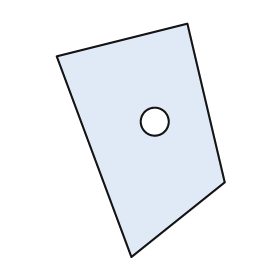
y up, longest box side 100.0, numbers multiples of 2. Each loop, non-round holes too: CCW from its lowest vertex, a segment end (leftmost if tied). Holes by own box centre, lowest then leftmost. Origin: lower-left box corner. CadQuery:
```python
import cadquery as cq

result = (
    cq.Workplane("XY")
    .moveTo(32.0, 0.0)
    .lineTo(72.0, 32.0)
    .lineTo(56.0, 100.0)
    .lineTo(0.0, 86.0)
    .close()
    .moveTo(42.0, 58.0)
    .circle(6.0)
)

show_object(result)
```